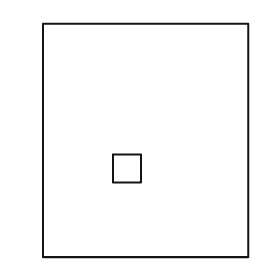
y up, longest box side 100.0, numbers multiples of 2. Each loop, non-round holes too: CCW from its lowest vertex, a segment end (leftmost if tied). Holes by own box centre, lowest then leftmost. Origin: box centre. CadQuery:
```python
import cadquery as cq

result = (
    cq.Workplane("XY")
    .moveTo(-44.0, -50.0)
    .lineTo(44.0, -50.0)
    .lineTo(44.0, 50.0)
    .lineTo(-44.0, 50.0)
    .close()
    .moveTo(-14.0, -18.0)
    .lineTo(-2.0, -18.0)
    .lineTo(-2.0, -6.0)
    .lineTo(-14.0, -6.0)
    .close()
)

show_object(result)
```